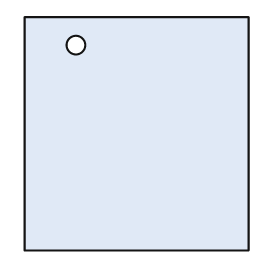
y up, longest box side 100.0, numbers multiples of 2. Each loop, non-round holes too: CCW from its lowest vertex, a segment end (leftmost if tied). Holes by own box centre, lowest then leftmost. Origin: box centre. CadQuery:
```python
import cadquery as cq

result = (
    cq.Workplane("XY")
    .moveTo(-48.0, -50.0)
    .lineTo(48.0, -50.0)
    .lineTo(48.0, 50.0)
    .lineTo(-48.0, 50.0)
    .close()
    .moveTo(-26.0, 38.0)
    .circle(4.0)
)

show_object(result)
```